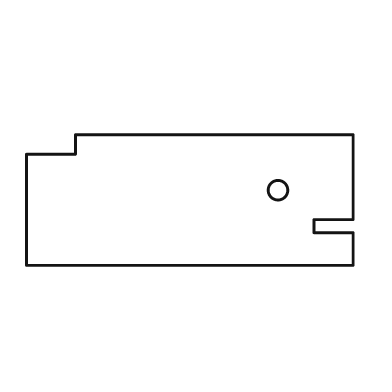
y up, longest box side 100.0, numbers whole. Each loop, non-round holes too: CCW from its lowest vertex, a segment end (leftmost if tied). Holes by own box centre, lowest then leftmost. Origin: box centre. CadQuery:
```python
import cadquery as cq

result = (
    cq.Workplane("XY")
    .moveTo(-50.0, -20.0)
    .lineTo(50.0, -20.0)
    .lineTo(50.0, -10.0)
    .lineTo(38.0, -10.0)
    .lineTo(38.0, -6.0)
    .lineTo(50.0, -6.0)
    .lineTo(50.0, 20.0)
    .lineTo(-35.0, 20.0)
    .lineTo(-35.0, 14.0)
    .lineTo(-50.0, 14.0)
    .close()
    .moveTo(27.0, 3.0)
    .circle(3.0)
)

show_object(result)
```